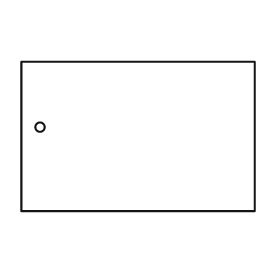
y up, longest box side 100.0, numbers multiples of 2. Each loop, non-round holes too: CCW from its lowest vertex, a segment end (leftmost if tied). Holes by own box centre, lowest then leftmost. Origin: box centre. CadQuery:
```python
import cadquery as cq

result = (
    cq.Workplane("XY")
    .moveTo(-50.0, -32.0)
    .lineTo(50.0, -32.0)
    .lineTo(50.0, 32.0)
    .lineTo(-50.0, 32.0)
    .close()
    .moveTo(-42.0, 4.0)
    .circle(2.0)
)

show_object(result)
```